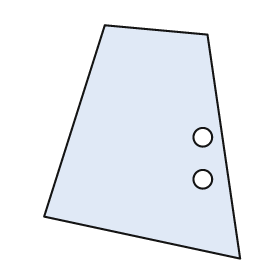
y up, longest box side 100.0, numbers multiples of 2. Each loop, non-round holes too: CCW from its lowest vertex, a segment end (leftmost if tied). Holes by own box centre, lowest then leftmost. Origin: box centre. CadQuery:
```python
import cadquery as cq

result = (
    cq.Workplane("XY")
    .moveTo(42.0, -50.0)
    .lineTo(28.0, 46.0)
    .lineTo(-16.0, 50.0)
    .lineTo(-42.0, -32.0)
    .close()
    .moveTo(26.0, -16.0)
    .circle(4.0)
    .moveTo(26.0, 2.0)
    .circle(4.0)
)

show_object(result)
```